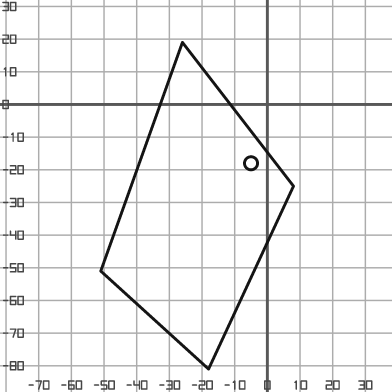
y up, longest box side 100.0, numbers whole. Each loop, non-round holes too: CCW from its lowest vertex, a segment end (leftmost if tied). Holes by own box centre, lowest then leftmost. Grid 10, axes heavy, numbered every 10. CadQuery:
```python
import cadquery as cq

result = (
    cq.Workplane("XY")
    .moveTo(-18.0, -81.0)
    .lineTo(8.0, -25.0)
    .lineTo(-26.0, 19.0)
    .lineTo(-51.0, -51.0)
    .close()
    .moveTo(-5.0, -18.0)
    .circle(2.0)
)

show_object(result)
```